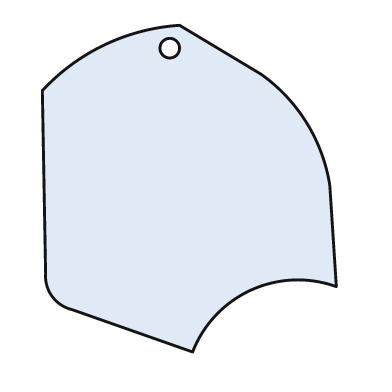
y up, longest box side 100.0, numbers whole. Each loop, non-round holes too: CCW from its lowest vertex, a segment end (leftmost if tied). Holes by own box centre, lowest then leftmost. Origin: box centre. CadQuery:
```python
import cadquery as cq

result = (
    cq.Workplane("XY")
    .moveTo(1.0, -50.0)
    .threePointArc((19.0, -31.0), (45.0, -30.0))
    .lineTo(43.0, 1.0)
    .threePointArc((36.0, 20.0), (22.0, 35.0))
    .lineTo(-3.0, 50.0)
    .threePointArc((-26.0, 44.0), (-45.0, 30.0))
    .lineTo(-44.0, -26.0)
    .threePointArc((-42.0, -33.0), (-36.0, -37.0))
    .close()
    .moveTo(-6.0, 43.0)
    .circle(3.0)
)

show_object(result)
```